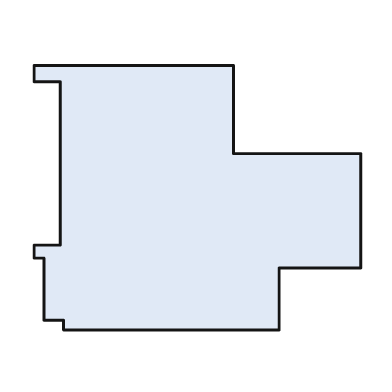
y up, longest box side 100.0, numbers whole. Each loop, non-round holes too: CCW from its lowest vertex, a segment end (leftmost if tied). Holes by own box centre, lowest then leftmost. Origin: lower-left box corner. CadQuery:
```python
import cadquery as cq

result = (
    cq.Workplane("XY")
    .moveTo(9.0, 0.0)
    .lineTo(75.0, 0.0)
    .lineTo(75.0, 19.0)
    .lineTo(100.0, 19.0)
    .lineTo(100.0, 54.0)
    .lineTo(61.0, 54.0)
    .lineTo(61.0, 81.0)
    .lineTo(0.0, 81.0)
    .lineTo(0.0, 76.0)
    .lineTo(8.0, 76.0)
    .lineTo(8.0, 26.0)
    .lineTo(0.0, 26.0)
    .lineTo(0.0, 22.0)
    .lineTo(3.0, 22.0)
    .lineTo(3.0, 3.0)
    .lineTo(9.0, 3.0)
    .close()
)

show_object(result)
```